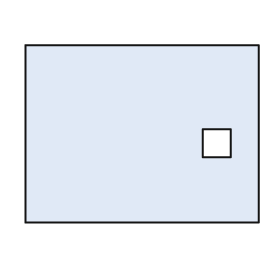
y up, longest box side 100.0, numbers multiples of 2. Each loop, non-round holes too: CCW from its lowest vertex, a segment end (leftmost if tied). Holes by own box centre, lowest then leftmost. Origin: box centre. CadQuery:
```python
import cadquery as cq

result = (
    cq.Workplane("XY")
    .moveTo(-50.0, -38.0)
    .lineTo(50.0, -38.0)
    .lineTo(50.0, 38.0)
    .lineTo(-50.0, 38.0)
    .close()
    .moveTo(26.0, -10.0)
    .lineTo(38.0, -10.0)
    .lineTo(38.0, 2.0)
    .lineTo(26.0, 2.0)
    .close()
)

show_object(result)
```